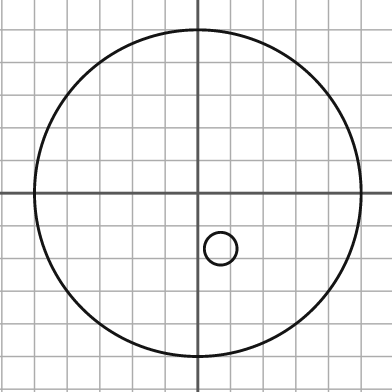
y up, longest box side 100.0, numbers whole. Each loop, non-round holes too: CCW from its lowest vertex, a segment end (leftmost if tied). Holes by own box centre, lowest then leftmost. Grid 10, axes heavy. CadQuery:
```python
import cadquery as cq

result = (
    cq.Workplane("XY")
    .moveTo(0.0, 0.0)
    .circle(50.0)
    .moveTo(7.0, -17.0)
    .circle(5.0)
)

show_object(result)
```